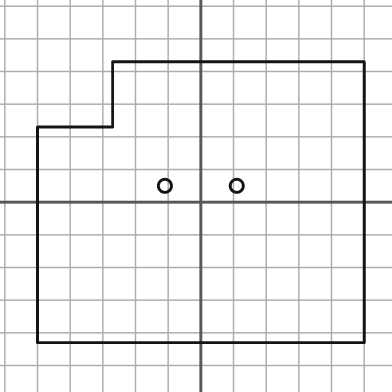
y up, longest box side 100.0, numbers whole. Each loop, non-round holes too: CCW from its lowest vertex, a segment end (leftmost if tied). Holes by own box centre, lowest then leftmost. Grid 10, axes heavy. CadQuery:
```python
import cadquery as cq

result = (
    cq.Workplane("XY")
    .moveTo(-50.0, -43.0)
    .lineTo(50.0, -43.0)
    .lineTo(50.0, 43.0)
    .lineTo(-27.0, 43.0)
    .lineTo(-27.0, 23.0)
    .lineTo(-50.0, 23.0)
    .close()
    .moveTo(-11.0, 5.0)
    .circle(2.0)
    .moveTo(11.0, 5.0)
    .circle(2.0)
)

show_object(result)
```